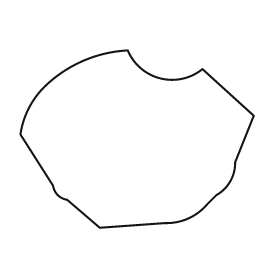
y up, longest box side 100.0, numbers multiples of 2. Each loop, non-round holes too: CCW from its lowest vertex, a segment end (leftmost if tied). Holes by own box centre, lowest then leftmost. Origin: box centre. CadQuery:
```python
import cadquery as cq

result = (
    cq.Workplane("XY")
    .moveTo(-16.0, -38.0)
    .lineTo(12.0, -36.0)
    .threePointArc((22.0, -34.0), (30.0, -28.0))
    .lineTo(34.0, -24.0)
    .threePointArc((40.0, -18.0), (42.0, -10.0))
    .lineTo(50.0, 10.0)
    .lineTo(28.0, 30.0)
    .threePointArc((10.0, 26.0), (-4.0, 38.0))
    .threePointArc((-22.0, 34.0), (-38.0, 24.0))
    .threePointArc((-46.0, 14.0), (-50.0, 2.0))
    .lineTo(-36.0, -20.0)
    .threePointArc((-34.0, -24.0), (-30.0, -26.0))
    .close()
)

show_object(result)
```